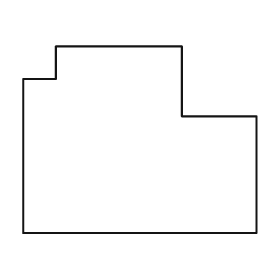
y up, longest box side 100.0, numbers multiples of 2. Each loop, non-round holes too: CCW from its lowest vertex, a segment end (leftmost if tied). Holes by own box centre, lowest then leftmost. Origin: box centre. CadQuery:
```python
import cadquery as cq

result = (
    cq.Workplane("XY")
    .moveTo(-50.0, -40.0)
    .lineTo(50.0, -40.0)
    .lineTo(50.0, 10.0)
    .lineTo(18.0, 10.0)
    .lineTo(18.0, 40.0)
    .lineTo(-36.0, 40.0)
    .lineTo(-36.0, 26.0)
    .lineTo(-50.0, 26.0)
    .close()
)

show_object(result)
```